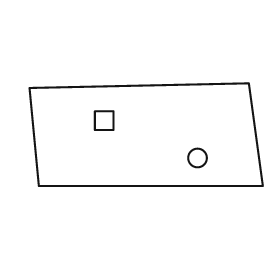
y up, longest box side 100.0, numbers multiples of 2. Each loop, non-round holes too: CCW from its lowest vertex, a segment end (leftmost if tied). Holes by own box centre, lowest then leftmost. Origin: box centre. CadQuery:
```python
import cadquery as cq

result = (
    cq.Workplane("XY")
    .moveTo(-46.0, -22.0)
    .lineTo(50.0, -22.0)
    .lineTo(44.0, 22.0)
    .lineTo(-50.0, 20.0)
    .close()
    .moveTo(22.0, -10.0)
    .circle(4.0)
    .moveTo(-22.0, 2.0)
    .lineTo(-14.0, 2.0)
    .lineTo(-14.0, 10.0)
    .lineTo(-22.0, 10.0)
    .close()
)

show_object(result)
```